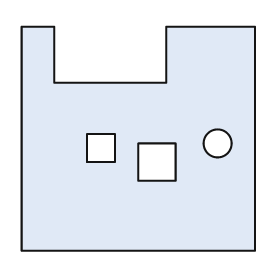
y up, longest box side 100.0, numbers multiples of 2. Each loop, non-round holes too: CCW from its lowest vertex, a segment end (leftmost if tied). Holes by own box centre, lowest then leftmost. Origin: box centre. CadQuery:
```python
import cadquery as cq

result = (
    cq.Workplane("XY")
    .moveTo(-50.0, -48.0)
    .lineTo(50.0, -48.0)
    .lineTo(50.0, 48.0)
    .lineTo(12.0, 48.0)
    .lineTo(12.0, 24.0)
    .lineTo(-36.0, 24.0)
    .lineTo(-36.0, 48.0)
    .lineTo(-50.0, 48.0)
    .close()
    .moveTo(0.0, -18.0)
    .lineTo(16.0, -18.0)
    .lineTo(16.0, -2.0)
    .lineTo(0.0, -2.0)
    .close()
    .moveTo(-22.0, -10.0)
    .lineTo(-10.0, -10.0)
    .lineTo(-10.0, 2.0)
    .lineTo(-22.0, 2.0)
    .close()
    .moveTo(34.0, -2.0)
    .circle(6.0)
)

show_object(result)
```